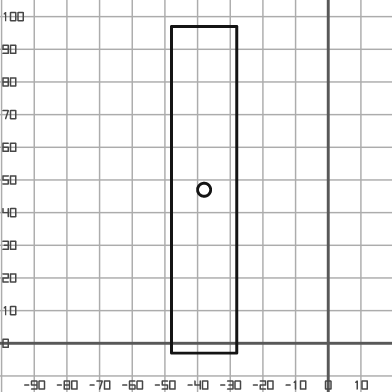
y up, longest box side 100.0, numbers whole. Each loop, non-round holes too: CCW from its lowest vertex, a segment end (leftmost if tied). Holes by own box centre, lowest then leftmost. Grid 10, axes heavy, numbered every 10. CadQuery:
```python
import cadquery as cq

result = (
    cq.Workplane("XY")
    .moveTo(-48.0, -3.0)
    .lineTo(-28.0, -3.0)
    .lineTo(-28.0, 97.0)
    .lineTo(-48.0, 97.0)
    .close()
    .moveTo(-38.0, 47.0)
    .circle(2.0)
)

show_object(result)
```